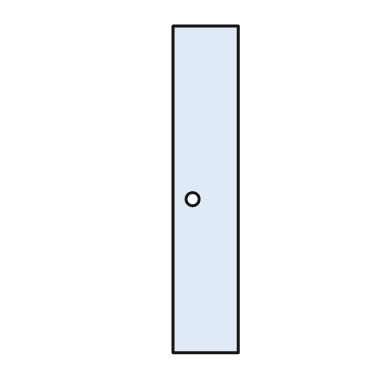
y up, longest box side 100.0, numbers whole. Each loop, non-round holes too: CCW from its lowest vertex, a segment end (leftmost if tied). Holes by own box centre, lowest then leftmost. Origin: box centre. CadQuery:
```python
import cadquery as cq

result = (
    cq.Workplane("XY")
    .moveTo(-10.0, -50.0)
    .lineTo(10.0, -50.0)
    .lineTo(10.0, 50.0)
    .lineTo(-10.0, 50.0)
    .close()
    .moveTo(-4.0, -3.0)
    .circle(2.0)
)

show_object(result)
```